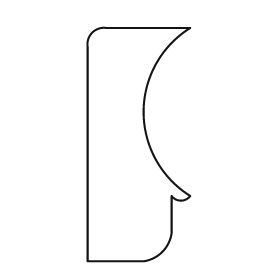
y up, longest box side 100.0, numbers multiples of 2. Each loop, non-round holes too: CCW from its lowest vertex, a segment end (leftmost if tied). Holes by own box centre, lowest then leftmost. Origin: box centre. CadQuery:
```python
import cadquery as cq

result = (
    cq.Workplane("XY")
    .moveTo(-22.0, -50.0)
    .lineTo(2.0, -50.0)
    .threePointArc((10.0, -46.0), (14.0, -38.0))
    .lineTo(14.0, -22.0)
    .threePointArc((18.0, -24.0), (22.0, -22.0))
    .threePointArc((2.0, 14.0), (22.0, 50.0))
    .lineTo(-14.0, 50.0)
    .threePointArc((-20.0, 48.0), (-22.0, 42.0))
    .close()
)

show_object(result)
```